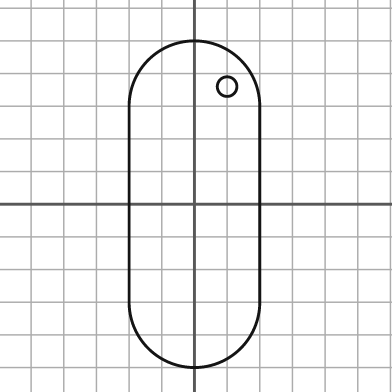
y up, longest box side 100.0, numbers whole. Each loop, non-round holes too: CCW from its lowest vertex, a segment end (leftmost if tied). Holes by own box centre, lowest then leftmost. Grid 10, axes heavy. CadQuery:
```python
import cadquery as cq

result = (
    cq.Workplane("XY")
    .moveTo(-20.0, -30.0)
    .threePointArc((0.0, -50.0), (20.0, -30.0))
    .lineTo(20.0, 30.0)
    .threePointArc((0.0, 50.0), (-20.0, 30.0))
    .close()
    .moveTo(10.0, 36.0)
    .circle(3.0)
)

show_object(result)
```